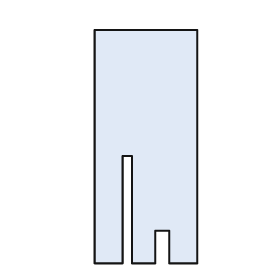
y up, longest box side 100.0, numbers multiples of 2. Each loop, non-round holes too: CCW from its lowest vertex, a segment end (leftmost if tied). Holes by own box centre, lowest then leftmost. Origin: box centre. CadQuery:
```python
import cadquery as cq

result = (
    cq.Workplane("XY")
    .moveTo(-22.0, -50.0)
    .lineTo(-10.0, -50.0)
    .lineTo(-10.0, -4.0)
    .lineTo(-6.0, -4.0)
    .lineTo(-6.0, -50.0)
    .lineTo(4.0, -50.0)
    .lineTo(4.0, -36.0)
    .lineTo(10.0, -36.0)
    .lineTo(10.0, -50.0)
    .lineTo(22.0, -50.0)
    .lineTo(22.0, 50.0)
    .lineTo(-22.0, 50.0)
    .close()
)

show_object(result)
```